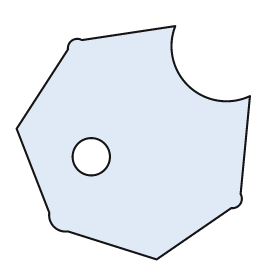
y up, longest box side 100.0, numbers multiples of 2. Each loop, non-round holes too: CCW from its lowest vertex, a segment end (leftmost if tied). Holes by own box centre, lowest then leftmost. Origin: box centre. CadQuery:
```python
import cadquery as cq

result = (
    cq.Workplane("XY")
    .moveTo(10.0, -50.0)
    .lineTo(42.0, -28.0)
    .threePointArc((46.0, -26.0), (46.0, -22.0))
    .lineTo(50.0, 20.0)
    .threePointArc((24.0, 24.0), (18.0, 50.0))
    .lineTo(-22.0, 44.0)
    .threePointArc((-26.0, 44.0), (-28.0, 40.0))
    .lineTo(-50.0, 6.0)
    .lineTo(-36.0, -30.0)
    .threePointArc((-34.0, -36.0), (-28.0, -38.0))
    .close()
    .moveTo(-18.0, -6.0)
    .circle(8.0)
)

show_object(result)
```